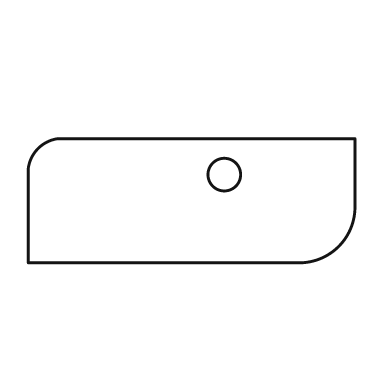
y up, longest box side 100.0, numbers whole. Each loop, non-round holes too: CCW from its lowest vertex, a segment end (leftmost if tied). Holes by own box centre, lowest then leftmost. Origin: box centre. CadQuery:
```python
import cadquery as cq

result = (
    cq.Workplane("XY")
    .moveTo(-50.0, -19.0)
    .lineTo(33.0, -19.0)
    .threePointArc((45.0, -14.0), (50.0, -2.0))
    .lineTo(50.0, 19.0)
    .lineTo(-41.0, 19.0)
    .threePointArc((-47.0, 16.0), (-50.0, 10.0))
    .close()
    .moveTo(10.0, 8.0)
    .circle(5.0)
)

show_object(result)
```